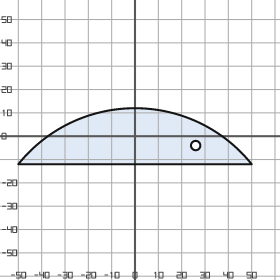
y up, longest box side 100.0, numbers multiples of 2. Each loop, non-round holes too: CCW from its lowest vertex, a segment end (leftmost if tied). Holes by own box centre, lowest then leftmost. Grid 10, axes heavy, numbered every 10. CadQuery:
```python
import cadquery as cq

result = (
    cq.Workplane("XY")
    .moveTo(-50.0, -12.0)
    .lineTo(50.0, -12.0)
    .threePointArc((0.0, 12.0), (-50.0, -12.0))
    .close()
    .moveTo(26.0, -4.0)
    .circle(2.0)
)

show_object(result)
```